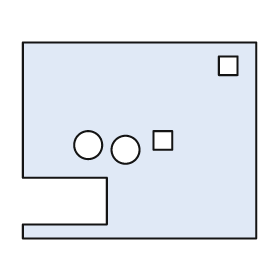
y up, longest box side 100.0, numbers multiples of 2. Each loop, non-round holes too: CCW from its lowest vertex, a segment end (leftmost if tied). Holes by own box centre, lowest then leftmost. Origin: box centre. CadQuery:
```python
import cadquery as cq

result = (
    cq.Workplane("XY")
    .moveTo(-50.0, -42.0)
    .lineTo(50.0, -42.0)
    .lineTo(50.0, 42.0)
    .lineTo(-50.0, 42.0)
    .lineTo(-50.0, -16.0)
    .lineTo(-14.0, -16.0)
    .lineTo(-14.0, -36.0)
    .lineTo(-50.0, -36.0)
    .close()
    .moveTo(-6.0, -4.0)
    .circle(6.0)
    .moveTo(-22.0, -2.0)
    .circle(6.0)
    .moveTo(6.0, -4.0)
    .lineTo(14.0, -4.0)
    .lineTo(14.0, 4.0)
    .lineTo(6.0, 4.0)
    .close()
    .moveTo(34.0, 28.0)
    .lineTo(42.0, 28.0)
    .lineTo(42.0, 36.0)
    .lineTo(34.0, 36.0)
    .close()
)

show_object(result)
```